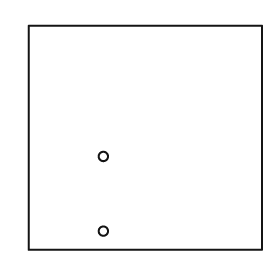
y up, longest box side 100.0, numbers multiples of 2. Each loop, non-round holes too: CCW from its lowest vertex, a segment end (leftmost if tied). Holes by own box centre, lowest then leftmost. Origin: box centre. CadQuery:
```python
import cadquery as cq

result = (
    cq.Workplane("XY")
    .moveTo(-50.0, -48.0)
    .lineTo(50.0, -48.0)
    .lineTo(50.0, 48.0)
    .lineTo(-50.0, 48.0)
    .close()
    .moveTo(-18.0, -40.0)
    .circle(2.0)
    .moveTo(-18.0, -8.0)
    .circle(2.0)
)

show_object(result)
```